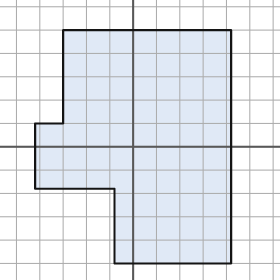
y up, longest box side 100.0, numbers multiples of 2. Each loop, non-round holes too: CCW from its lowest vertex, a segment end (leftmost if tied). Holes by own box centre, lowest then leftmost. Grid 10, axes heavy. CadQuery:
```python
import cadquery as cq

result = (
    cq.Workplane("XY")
    .moveTo(-8.0, -50.0)
    .lineTo(42.0, -50.0)
    .lineTo(42.0, 50.0)
    .lineTo(-30.0, 50.0)
    .lineTo(-30.0, 10.0)
    .lineTo(-42.0, 10.0)
    .lineTo(-42.0, -18.0)
    .lineTo(-8.0, -18.0)
    .close()
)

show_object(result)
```